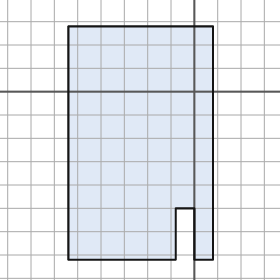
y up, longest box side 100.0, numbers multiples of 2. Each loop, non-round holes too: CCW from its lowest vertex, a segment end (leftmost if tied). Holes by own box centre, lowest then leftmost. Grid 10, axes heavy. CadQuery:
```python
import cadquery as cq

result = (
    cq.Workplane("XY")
    .moveTo(-54.0, -72.0)
    .lineTo(-8.0, -72.0)
    .lineTo(-8.0, -50.0)
    .lineTo(0.0, -50.0)
    .lineTo(0.0, -72.0)
    .lineTo(8.0, -72.0)
    .lineTo(8.0, 28.0)
    .lineTo(-54.0, 28.0)
    .close()
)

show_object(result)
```